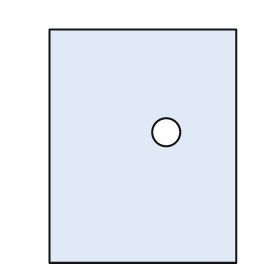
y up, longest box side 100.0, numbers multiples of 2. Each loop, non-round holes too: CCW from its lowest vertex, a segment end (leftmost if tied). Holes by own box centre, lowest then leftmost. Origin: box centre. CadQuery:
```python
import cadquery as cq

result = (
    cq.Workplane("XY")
    .moveTo(-40.0, -50.0)
    .lineTo(40.0, -50.0)
    .lineTo(40.0, 50.0)
    .lineTo(-40.0, 50.0)
    .close()
    .moveTo(10.0, 6.0)
    .circle(6.0)
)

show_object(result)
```